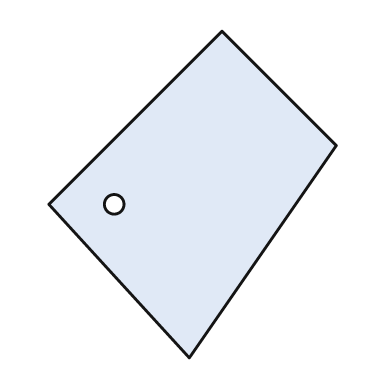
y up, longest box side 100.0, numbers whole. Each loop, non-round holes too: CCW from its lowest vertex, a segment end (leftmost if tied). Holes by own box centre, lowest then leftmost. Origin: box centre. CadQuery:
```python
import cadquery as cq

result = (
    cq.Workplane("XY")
    .moveTo(-1.0, -50.0)
    .lineTo(44.0, 15.0)
    .lineTo(9.0, 50.0)
    .lineTo(-44.0, -3.0)
    .close()
    .moveTo(-24.0, -3.0)
    .circle(3.0)
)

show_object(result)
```